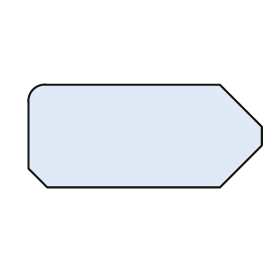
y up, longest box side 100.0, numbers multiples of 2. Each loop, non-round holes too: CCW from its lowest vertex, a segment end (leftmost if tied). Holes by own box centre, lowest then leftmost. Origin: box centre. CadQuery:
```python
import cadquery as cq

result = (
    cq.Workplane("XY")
    .moveTo(-42.0, -22.0)
    .lineTo(32.0, -22.0)
    .lineTo(50.0, -4.0)
    .lineTo(50.0, 4.0)
    .lineTo(32.0, 22.0)
    .lineTo(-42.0, 22.0)
    .threePointArc((-48.0, 20.0), (-50.0, 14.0))
    .lineTo(-50.0, -14.0)
    .close()
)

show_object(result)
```